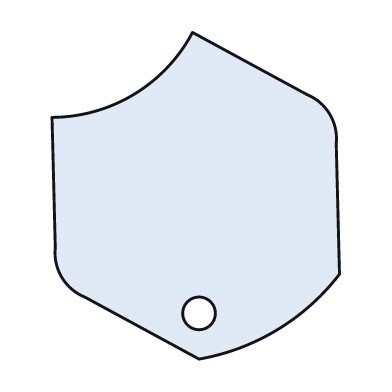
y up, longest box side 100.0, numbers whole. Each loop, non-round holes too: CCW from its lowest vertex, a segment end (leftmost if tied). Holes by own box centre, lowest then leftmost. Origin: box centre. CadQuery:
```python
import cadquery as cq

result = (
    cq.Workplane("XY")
    .moveTo(1.0, -50.0)
    .threePointArc((25.0, -41.0), (44.0, -24.0))
    .lineTo(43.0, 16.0)
    .threePointArc((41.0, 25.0), (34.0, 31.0))
    .lineTo(-1.0, 50.0)
    .threePointArc((-19.0, 31.0), (-44.0, 24.0))
    .lineTo(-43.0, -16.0)
    .threePointArc((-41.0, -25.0), (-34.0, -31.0))
    .close()
    .moveTo(1.0, -36.0)
    .circle(5.0)
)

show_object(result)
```